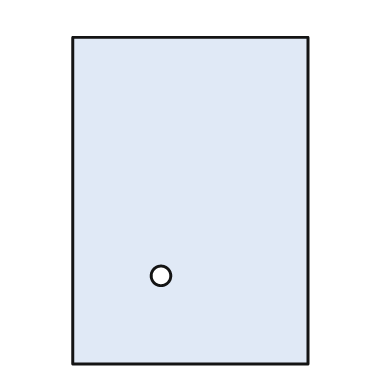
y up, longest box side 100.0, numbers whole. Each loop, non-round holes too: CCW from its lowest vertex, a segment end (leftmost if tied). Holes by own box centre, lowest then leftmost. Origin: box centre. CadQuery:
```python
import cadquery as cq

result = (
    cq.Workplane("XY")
    .moveTo(-36.0, -50.0)
    .lineTo(36.0, -50.0)
    .lineTo(36.0, 50.0)
    .lineTo(-36.0, 50.0)
    .close()
    .moveTo(-9.0, -23.0)
    .circle(3.0)
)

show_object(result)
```